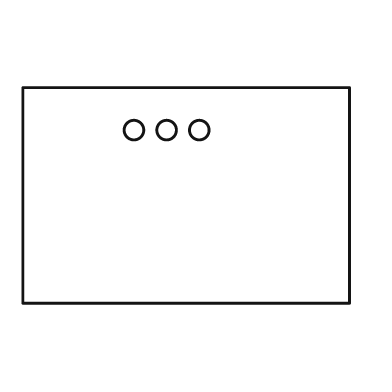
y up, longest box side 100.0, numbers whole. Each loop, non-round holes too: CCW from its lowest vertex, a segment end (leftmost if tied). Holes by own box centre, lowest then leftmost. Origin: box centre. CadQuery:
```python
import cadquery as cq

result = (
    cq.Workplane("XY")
    .moveTo(-50.0, -33.0)
    .lineTo(50.0, -33.0)
    .lineTo(50.0, 33.0)
    .lineTo(-50.0, 33.0)
    .close()
    .moveTo(-16.0, 20.0)
    .circle(3.0)
    .moveTo(-6.0, 20.0)
    .circle(3.0)
    .moveTo(4.0, 20.0)
    .circle(3.0)
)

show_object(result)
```